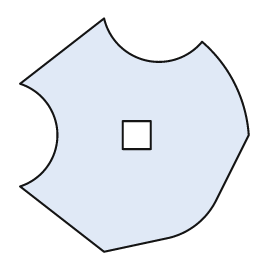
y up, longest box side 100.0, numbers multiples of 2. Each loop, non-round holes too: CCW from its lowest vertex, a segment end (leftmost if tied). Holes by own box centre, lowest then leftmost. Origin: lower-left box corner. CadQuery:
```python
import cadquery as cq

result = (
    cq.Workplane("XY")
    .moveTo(36.0, 0.0)
    .lineTo(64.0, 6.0)
    .threePointArc((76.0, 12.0), (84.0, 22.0))
    .lineTo(98.0, 50.0)
    .threePointArc((92.0, 72.0), (78.0, 90.0))
    .threePointArc((54.0, 82.0), (36.0, 100.0))
    .lineTo(0.0, 72.0)
    .threePointArc((16.0, 50.0), (0.0, 28.0))
    .close()
    .moveTo(44.0, 44.0)
    .lineTo(56.0, 44.0)
    .lineTo(56.0, 56.0)
    .lineTo(44.0, 56.0)
    .close()
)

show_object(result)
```